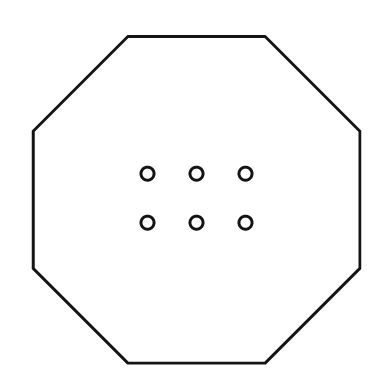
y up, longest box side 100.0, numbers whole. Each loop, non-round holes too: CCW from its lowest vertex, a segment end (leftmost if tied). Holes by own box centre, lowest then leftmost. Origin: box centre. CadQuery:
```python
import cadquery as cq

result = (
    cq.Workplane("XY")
    .moveTo(-21.0, -50.0)
    .lineTo(21.0, -50.0)
    .lineTo(50.0, -21.0)
    .lineTo(50.0, 21.0)
    .lineTo(21.0, 50.0)
    .lineTo(-21.0, 50.0)
    .lineTo(-50.0, 21.0)
    .lineTo(-50.0, -21.0)
    .close()
    .moveTo(-15.0, -7.0)
    .circle(2.0)
    .moveTo(0.0, -7.0)
    .circle(2.0)
    .moveTo(15.0, -7.0)
    .circle(2.0)
    .moveTo(-15.0, 8.0)
    .circle(2.0)
    .moveTo(0.0, 8.0)
    .circle(2.0)
    .moveTo(15.0, 8.0)
    .circle(2.0)
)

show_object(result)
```